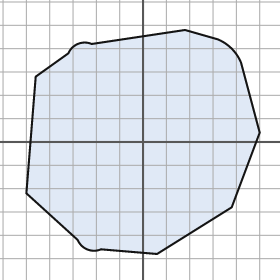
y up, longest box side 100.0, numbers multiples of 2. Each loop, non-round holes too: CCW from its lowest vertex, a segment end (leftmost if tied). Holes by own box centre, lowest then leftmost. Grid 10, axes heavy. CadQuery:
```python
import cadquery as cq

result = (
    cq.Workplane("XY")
    .moveTo(6.0, -48.0)
    .lineTo(38.0, -28.0)
    .lineTo(50.0, 4.0)
    .lineTo(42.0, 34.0)
    .threePointArc((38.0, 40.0), (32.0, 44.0))
    .lineTo(18.0, 48.0)
    .lineTo(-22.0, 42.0)
    .threePointArc((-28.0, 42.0), (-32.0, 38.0))
    .lineTo(-46.0, 28.0)
    .lineTo(-50.0, -22.0)
    .lineTo(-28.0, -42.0)
    .threePointArc((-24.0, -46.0), (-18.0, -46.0))
    .close()
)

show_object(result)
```